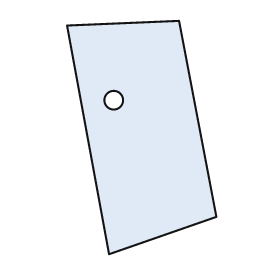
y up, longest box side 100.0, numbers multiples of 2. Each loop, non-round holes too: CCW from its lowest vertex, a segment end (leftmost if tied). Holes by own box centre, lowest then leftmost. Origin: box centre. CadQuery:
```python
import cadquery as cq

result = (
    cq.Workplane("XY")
    .moveTo(-14.0, -50.0)
    .lineTo(32.0, -34.0)
    .lineTo(16.0, 50.0)
    .lineTo(-32.0, 48.0)
    .close()
    .moveTo(-12.0, 16.0)
    .circle(4.0)
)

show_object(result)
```